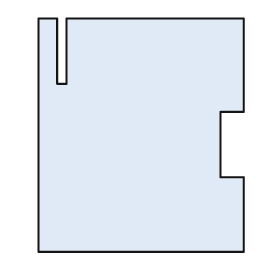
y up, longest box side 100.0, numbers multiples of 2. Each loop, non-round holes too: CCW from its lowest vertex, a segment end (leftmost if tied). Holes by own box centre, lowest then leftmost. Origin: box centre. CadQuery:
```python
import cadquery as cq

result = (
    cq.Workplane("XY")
    .moveTo(-44.0, -50.0)
    .lineTo(44.0, -50.0)
    .lineTo(44.0, -18.0)
    .lineTo(34.0, -18.0)
    .lineTo(34.0, 10.0)
    .lineTo(44.0, 10.0)
    .lineTo(44.0, 50.0)
    .lineTo(-32.0, 50.0)
    .lineTo(-32.0, 22.0)
    .lineTo(-36.0, 22.0)
    .lineTo(-36.0, 50.0)
    .lineTo(-44.0, 50.0)
    .close()
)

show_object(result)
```